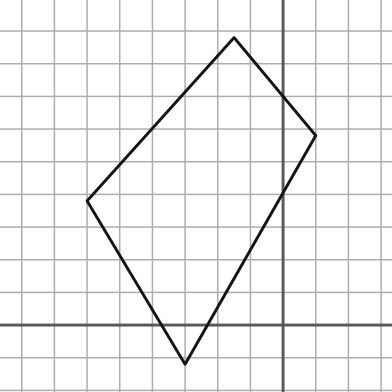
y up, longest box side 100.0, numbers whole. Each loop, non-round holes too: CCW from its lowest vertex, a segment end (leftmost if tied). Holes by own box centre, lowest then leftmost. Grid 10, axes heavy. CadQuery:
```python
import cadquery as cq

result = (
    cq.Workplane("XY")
    .moveTo(-30.0, -12.0)
    .lineTo(10.0, 58.0)
    .lineTo(-15.0, 88.0)
    .lineTo(-60.0, 38.0)
    .close()
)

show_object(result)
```